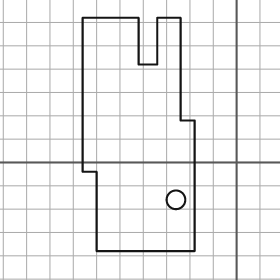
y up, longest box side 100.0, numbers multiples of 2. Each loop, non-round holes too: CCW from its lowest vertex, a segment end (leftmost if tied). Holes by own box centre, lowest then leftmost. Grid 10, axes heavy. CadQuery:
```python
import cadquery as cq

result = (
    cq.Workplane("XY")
    .moveTo(-60.0, -38.0)
    .lineTo(-18.0, -38.0)
    .lineTo(-18.0, 18.0)
    .lineTo(-24.0, 18.0)
    .lineTo(-24.0, 62.0)
    .lineTo(-34.0, 62.0)
    .lineTo(-34.0, 42.0)
    .lineTo(-42.0, 42.0)
    .lineTo(-42.0, 62.0)
    .lineTo(-66.0, 62.0)
    .lineTo(-66.0, -4.0)
    .lineTo(-60.0, -4.0)
    .close()
    .moveTo(-26.0, -16.0)
    .circle(4.0)
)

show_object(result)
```